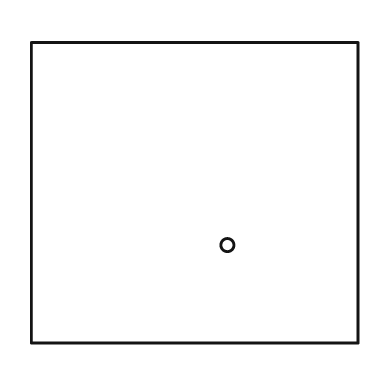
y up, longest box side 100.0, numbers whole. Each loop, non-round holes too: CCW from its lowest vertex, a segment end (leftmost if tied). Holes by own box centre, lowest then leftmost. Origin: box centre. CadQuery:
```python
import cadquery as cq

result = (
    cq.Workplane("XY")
    .moveTo(-50.0, -46.0)
    .lineTo(50.0, -46.0)
    .lineTo(50.0, 46.0)
    .lineTo(-50.0, 46.0)
    .close()
    .moveTo(10.0, -16.0)
    .circle(2.0)
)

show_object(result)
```